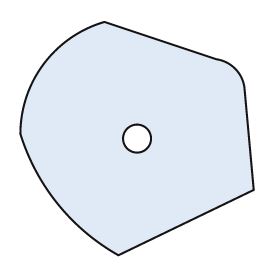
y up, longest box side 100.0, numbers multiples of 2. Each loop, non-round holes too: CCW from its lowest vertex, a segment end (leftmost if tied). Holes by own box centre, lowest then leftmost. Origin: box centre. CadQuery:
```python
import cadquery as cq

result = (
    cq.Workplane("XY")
    .moveTo(-8.0, -50.0)
    .lineTo(50.0, -22.0)
    .lineTo(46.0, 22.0)
    .threePointArc((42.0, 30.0), (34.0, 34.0))
    .lineTo(-14.0, 50.0)
    .threePointArc((-40.0, 32.0), (-50.0, 2.0))
    .threePointArc((-34.0, -28.0), (-8.0, -50.0))
    .close()
    .moveTo(0.0, 0.0)
    .circle(6.0)
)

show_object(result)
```